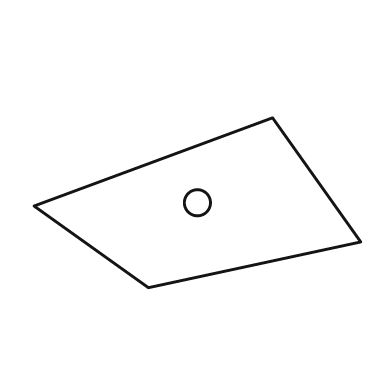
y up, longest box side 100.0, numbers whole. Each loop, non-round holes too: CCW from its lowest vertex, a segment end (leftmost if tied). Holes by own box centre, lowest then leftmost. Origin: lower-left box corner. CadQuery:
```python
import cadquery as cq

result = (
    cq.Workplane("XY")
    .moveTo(35.0, 0.0)
    .lineTo(100.0, 14.0)
    .lineTo(73.0, 52.0)
    .lineTo(0.0, 25.0)
    .close()
    .moveTo(50.0, 26.0)
    .circle(4.0)
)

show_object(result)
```